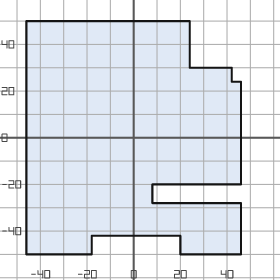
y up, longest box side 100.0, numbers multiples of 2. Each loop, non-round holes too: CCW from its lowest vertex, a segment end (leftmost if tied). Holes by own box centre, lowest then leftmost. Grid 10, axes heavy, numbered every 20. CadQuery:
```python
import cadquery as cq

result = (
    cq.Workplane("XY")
    .moveTo(-46.0, -50.0)
    .lineTo(-18.0, -50.0)
    .lineTo(-18.0, -42.0)
    .lineTo(20.0, -42.0)
    .lineTo(20.0, -50.0)
    .lineTo(46.0, -50.0)
    .lineTo(46.0, -28.0)
    .lineTo(8.0, -28.0)
    .lineTo(8.0, -20.0)
    .lineTo(46.0, -20.0)
    .lineTo(46.0, 24.0)
    .lineTo(42.0, 24.0)
    .lineTo(42.0, 30.0)
    .lineTo(24.0, 30.0)
    .lineTo(24.0, 50.0)
    .lineTo(-46.0, 50.0)
    .close()
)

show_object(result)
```